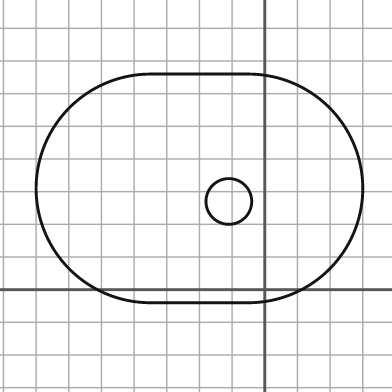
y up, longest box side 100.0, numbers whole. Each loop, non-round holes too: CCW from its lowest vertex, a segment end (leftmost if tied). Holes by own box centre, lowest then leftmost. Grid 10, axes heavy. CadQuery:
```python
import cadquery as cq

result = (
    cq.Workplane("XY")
    .moveTo(-35.0, -4.0)
    .lineTo(-5.0, -4.0)
    .threePointArc((30.0, 31.0), (-5.0, 66.0))
    .lineTo(-35.0, 66.0)
    .threePointArc((-70.0, 31.0), (-35.0, -4.0))
    .close()
    .moveTo(-11.0, 27.0)
    .circle(7.0)
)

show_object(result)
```